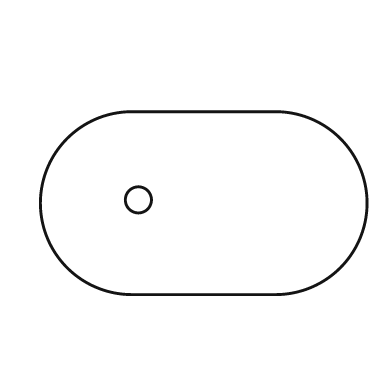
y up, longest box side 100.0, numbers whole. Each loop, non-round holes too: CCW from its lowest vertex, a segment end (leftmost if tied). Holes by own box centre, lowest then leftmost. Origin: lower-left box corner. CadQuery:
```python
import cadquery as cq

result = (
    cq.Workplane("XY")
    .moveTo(28.0, 0.0)
    .lineTo(72.0, 0.0)
    .threePointArc((100.0, 28.0), (72.0, 56.0))
    .lineTo(28.0, 56.0)
    .threePointArc((0.0, 28.0), (28.0, 0.0))
    .close()
    .moveTo(30.0, 29.0)
    .circle(4.0)
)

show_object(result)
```